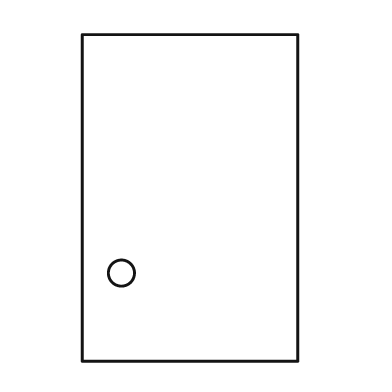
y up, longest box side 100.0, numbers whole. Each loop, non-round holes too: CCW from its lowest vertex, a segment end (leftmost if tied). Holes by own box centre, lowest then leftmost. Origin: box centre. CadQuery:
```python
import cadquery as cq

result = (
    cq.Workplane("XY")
    .moveTo(-33.0, -50.0)
    .lineTo(33.0, -50.0)
    .lineTo(33.0, 50.0)
    .lineTo(-33.0, 50.0)
    .close()
    .moveTo(-21.0, -23.0)
    .circle(4.0)
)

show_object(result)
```